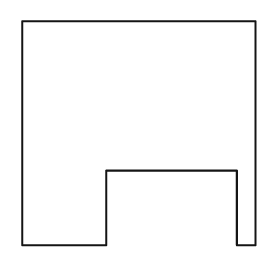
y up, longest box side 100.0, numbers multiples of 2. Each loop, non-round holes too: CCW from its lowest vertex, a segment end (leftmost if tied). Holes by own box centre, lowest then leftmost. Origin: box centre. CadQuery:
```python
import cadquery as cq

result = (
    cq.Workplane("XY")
    .moveTo(-50.0, -48.0)
    .lineTo(-14.0, -48.0)
    .lineTo(-14.0, -16.0)
    .lineTo(42.0, -16.0)
    .lineTo(42.0, -48.0)
    .lineTo(50.0, -48.0)
    .lineTo(50.0, 48.0)
    .lineTo(-50.0, 48.0)
    .close()
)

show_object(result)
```